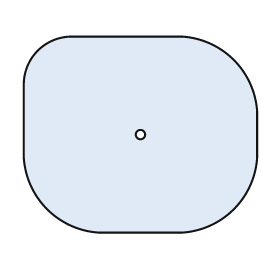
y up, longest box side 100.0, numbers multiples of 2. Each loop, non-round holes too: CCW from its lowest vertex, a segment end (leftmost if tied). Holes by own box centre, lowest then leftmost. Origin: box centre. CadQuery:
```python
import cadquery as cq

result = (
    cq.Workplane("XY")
    .moveTo(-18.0, -42.0)
    .lineTo(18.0, -42.0)
    .threePointArc((40.0, -32.0), (50.0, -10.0))
    .lineTo(50.0, 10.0)
    .threePointArc((40.0, 32.0), (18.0, 42.0))
    .lineTo(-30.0, 42.0)
    .threePointArc((-44.0, 36.0), (-50.0, 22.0))
    .lineTo(-50.0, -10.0)
    .threePointArc((-40.0, -32.0), (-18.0, -42.0))
    .close()
    .moveTo(0.0, 0.0)
    .circle(2.0)
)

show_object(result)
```